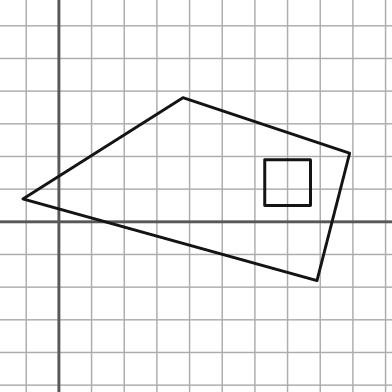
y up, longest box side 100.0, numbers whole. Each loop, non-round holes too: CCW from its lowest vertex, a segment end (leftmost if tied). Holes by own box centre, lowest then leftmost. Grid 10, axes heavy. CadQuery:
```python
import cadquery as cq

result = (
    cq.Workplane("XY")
    .moveTo(79.0, -18.0)
    .lineTo(89.0, 21.0)
    .lineTo(38.0, 38.0)
    .lineTo(-11.0, 7.0)
    .close()
    .moveTo(63.0, 5.0)
    .lineTo(77.0, 5.0)
    .lineTo(77.0, 19.0)
    .lineTo(63.0, 19.0)
    .close()
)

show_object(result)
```